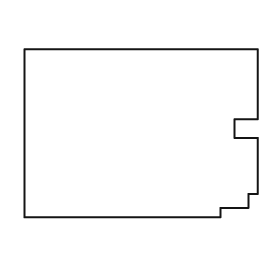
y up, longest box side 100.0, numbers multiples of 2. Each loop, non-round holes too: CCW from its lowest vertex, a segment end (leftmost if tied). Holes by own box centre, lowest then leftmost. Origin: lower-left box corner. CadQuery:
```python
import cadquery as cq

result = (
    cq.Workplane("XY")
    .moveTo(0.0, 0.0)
    .lineTo(84.0, 0.0)
    .lineTo(84.0, 4.0)
    .lineTo(96.0, 4.0)
    .lineTo(96.0, 10.0)
    .lineTo(100.0, 10.0)
    .lineTo(100.0, 34.0)
    .lineTo(90.0, 34.0)
    .lineTo(90.0, 42.0)
    .lineTo(100.0, 42.0)
    .lineTo(100.0, 72.0)
    .lineTo(0.0, 72.0)
    .close()
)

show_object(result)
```